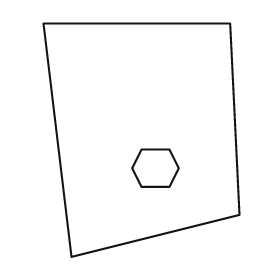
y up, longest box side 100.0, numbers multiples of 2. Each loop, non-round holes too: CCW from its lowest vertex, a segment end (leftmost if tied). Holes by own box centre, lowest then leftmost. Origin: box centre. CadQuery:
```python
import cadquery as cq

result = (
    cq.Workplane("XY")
    .moveTo(-30.0, -50.0)
    .lineTo(42.0, -32.0)
    .lineTo(38.0, 50.0)
    .lineTo(-42.0, 50.0)
    .close()
    .moveTo(0.0, -20.0)
    .lineTo(12.0, -20.0)
    .lineTo(16.0, -12.0)
    .lineTo(12.0, -4.0)
    .lineTo(0.0, -4.0)
    .lineTo(-4.0, -12.0)
    .close()
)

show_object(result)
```